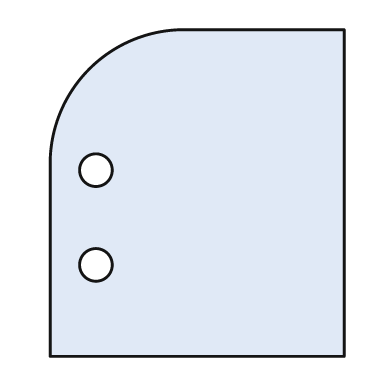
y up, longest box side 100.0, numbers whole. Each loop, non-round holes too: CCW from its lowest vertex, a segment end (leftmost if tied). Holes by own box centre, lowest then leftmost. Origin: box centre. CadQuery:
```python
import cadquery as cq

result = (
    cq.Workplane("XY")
    .moveTo(-45.0, -50.0)
    .lineTo(45.0, -50.0)
    .lineTo(45.0, 50.0)
    .lineTo(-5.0, 50.0)
    .threePointArc((-33.0, 38.0), (-45.0, 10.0))
    .close()
    .moveTo(-31.0, -22.0)
    .circle(5.0)
    .moveTo(-31.0, 7.0)
    .circle(5.0)
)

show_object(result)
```